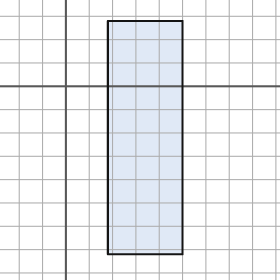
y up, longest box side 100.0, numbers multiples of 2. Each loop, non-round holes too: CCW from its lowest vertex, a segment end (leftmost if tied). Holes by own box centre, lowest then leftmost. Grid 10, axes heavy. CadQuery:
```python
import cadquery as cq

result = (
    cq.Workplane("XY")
    .moveTo(18.0, -72.0)
    .lineTo(50.0, -72.0)
    .lineTo(50.0, 28.0)
    .lineTo(18.0, 28.0)
    .close()
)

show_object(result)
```